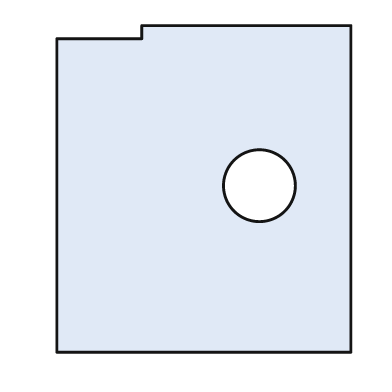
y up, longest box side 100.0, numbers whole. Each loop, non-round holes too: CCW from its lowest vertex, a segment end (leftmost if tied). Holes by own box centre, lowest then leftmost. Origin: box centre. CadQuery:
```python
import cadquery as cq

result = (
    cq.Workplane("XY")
    .moveTo(-45.0, -50.0)
    .lineTo(45.0, -50.0)
    .lineTo(45.0, 50.0)
    .lineTo(-19.0, 50.0)
    .lineTo(-19.0, 46.0)
    .lineTo(-45.0, 46.0)
    .close()
    .moveTo(17.0, 1.0)
    .circle(11.0)
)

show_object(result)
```